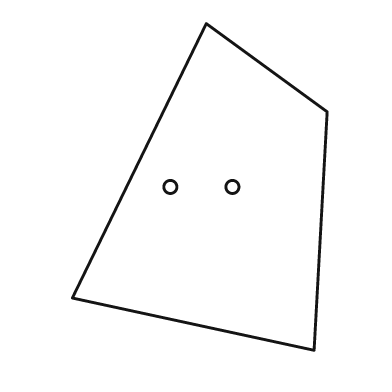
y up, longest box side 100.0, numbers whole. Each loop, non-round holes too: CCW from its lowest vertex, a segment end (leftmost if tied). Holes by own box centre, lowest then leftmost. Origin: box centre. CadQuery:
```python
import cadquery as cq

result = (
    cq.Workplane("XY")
    .moveTo(35.0, -50.0)
    .lineTo(39.0, 23.0)
    .lineTo(2.0, 50.0)
    .lineTo(-39.0, -34.0)
    .close()
    .moveTo(-9.0, 0.0)
    .circle(2.0)
    .moveTo(10.0, 0.0)
    .circle(2.0)
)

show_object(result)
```